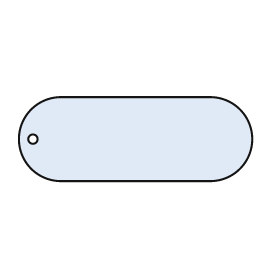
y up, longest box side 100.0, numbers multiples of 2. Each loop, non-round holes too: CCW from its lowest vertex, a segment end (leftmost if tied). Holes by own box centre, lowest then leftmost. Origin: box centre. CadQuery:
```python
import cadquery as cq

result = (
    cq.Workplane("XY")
    .moveTo(-32.0, -18.0)
    .lineTo(32.0, -18.0)
    .threePointArc((50.0, 0.0), (32.0, 18.0))
    .lineTo(-32.0, 18.0)
    .threePointArc((-50.0, 0.0), (-32.0, -18.0))
    .close()
    .moveTo(-44.0, 0.0)
    .circle(2.0)
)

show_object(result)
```